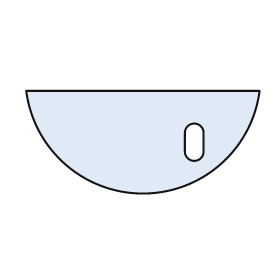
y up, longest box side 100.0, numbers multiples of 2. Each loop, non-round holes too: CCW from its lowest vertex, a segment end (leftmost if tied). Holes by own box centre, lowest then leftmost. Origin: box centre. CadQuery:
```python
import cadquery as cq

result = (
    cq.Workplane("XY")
    .moveTo(-50.0, 22.0)
    .threePointArc((0.0, -22.0), (50.0, 22.0))
    .close()
    .moveTo(18.0, -4.0)
    .threePointArc((22.0, -8.0), (26.0, -4.0))
    .lineTo(26.0, 4.0)
    .threePointArc((22.0, 8.0), (18.0, 4.0))
    .close()
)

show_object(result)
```